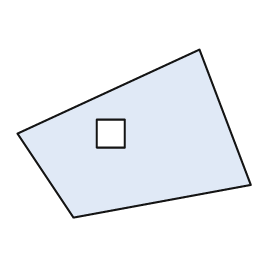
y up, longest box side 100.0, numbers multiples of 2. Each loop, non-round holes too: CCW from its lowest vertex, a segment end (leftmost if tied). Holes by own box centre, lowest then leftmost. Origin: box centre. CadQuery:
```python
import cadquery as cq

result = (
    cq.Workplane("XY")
    .moveTo(-26.0, -36.0)
    .lineTo(50.0, -22.0)
    .lineTo(28.0, 36.0)
    .lineTo(-50.0, 0.0)
    .close()
    .moveTo(-16.0, -6.0)
    .lineTo(-4.0, -6.0)
    .lineTo(-4.0, 6.0)
    .lineTo(-16.0, 6.0)
    .close()
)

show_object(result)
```